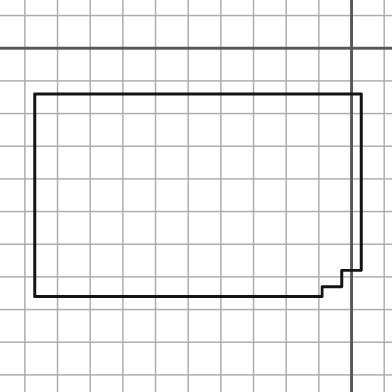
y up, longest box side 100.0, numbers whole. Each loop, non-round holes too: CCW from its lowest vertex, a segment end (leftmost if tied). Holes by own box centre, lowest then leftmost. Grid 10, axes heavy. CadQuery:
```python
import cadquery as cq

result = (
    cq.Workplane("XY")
    .moveTo(-97.0, -76.0)
    .lineTo(-9.0, -76.0)
    .lineTo(-9.0, -73.0)
    .lineTo(-3.0, -73.0)
    .lineTo(-3.0, -68.0)
    .lineTo(3.0, -68.0)
    .lineTo(3.0, -14.0)
    .lineTo(-97.0, -14.0)
    .close()
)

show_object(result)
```